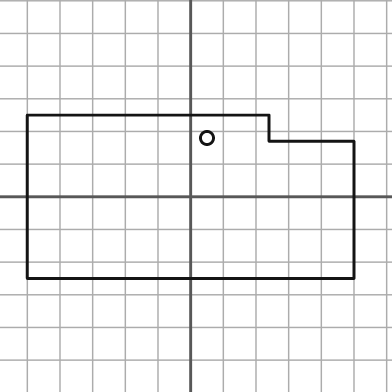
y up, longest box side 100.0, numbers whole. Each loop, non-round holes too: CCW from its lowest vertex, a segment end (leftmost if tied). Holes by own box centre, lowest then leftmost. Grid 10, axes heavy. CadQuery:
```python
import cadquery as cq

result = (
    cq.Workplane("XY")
    .moveTo(-50.0, -25.0)
    .lineTo(50.0, -25.0)
    .lineTo(50.0, 17.0)
    .lineTo(24.0, 17.0)
    .lineTo(24.0, 25.0)
    .lineTo(-50.0, 25.0)
    .close()
    .moveTo(5.0, 18.0)
    .circle(2.0)
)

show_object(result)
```